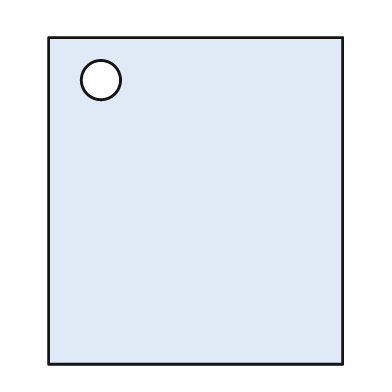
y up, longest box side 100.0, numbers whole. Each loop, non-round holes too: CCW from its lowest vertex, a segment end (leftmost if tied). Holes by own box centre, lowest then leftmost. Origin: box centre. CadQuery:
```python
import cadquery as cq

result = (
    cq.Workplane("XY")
    .moveTo(-45.0, -50.0)
    .lineTo(45.0, -50.0)
    .lineTo(45.0, 50.0)
    .lineTo(-45.0, 50.0)
    .close()
    .moveTo(-29.0, 37.0)
    .circle(6.0)
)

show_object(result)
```